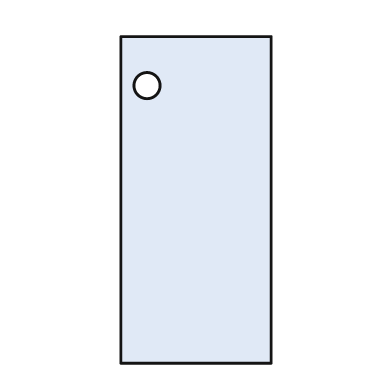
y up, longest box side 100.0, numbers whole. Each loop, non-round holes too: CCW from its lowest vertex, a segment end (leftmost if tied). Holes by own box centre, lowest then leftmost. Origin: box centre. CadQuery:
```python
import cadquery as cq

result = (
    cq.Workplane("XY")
    .moveTo(-23.0, -50.0)
    .lineTo(23.0, -50.0)
    .lineTo(23.0, 50.0)
    .lineTo(-23.0, 50.0)
    .close()
    .moveTo(-15.0, 35.0)
    .circle(4.0)
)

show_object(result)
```